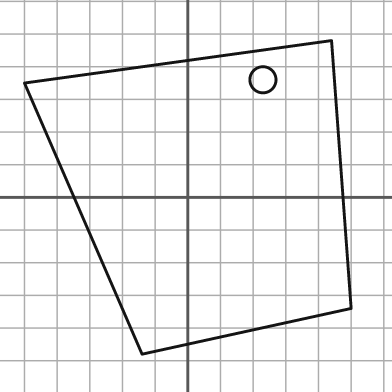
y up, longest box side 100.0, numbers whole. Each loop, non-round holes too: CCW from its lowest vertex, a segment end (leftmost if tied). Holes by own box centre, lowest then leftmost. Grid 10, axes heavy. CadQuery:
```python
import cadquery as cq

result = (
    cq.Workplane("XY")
    .moveTo(-14.0, -48.0)
    .lineTo(50.0, -34.0)
    .lineTo(44.0, 48.0)
    .lineTo(-50.0, 35.0)
    .close()
    .moveTo(23.0, 36.0)
    .circle(4.0)
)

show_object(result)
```